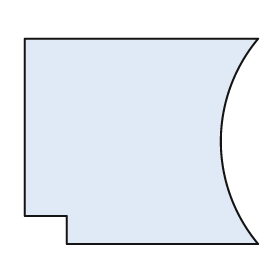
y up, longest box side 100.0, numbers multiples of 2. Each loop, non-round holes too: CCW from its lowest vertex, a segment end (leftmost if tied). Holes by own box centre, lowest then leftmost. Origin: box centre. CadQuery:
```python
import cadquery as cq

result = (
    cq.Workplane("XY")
    .moveTo(-32.0, -44.0)
    .lineTo(50.0, -44.0)
    .threePointArc((34.0, 0.0), (50.0, 44.0))
    .lineTo(-50.0, 44.0)
    .lineTo(-50.0, -32.0)
    .lineTo(-32.0, -32.0)
    .close()
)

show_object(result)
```